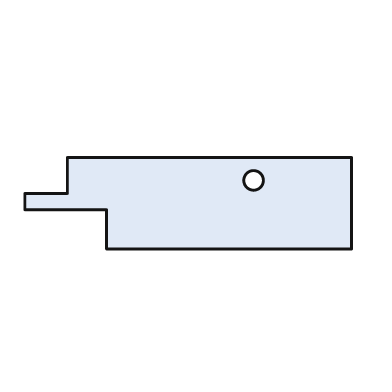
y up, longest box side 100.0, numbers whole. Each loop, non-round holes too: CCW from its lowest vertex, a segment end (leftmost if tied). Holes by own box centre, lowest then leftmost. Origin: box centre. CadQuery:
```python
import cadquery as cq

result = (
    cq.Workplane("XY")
    .moveTo(-25.0, -14.0)
    .lineTo(50.0, -14.0)
    .lineTo(50.0, 14.0)
    .lineTo(-37.0, 14.0)
    .lineTo(-37.0, 3.0)
    .lineTo(-50.0, 3.0)
    .lineTo(-50.0, -2.0)
    .lineTo(-25.0, -2.0)
    .close()
    .moveTo(20.0, 7.0)
    .circle(3.0)
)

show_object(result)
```